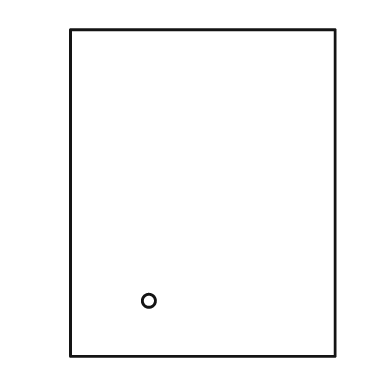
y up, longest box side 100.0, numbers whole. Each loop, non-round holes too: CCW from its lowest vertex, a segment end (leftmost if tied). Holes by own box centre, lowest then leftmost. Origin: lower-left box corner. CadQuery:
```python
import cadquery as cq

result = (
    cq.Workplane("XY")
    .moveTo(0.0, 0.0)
    .lineTo(81.0, 0.0)
    .lineTo(81.0, 100.0)
    .lineTo(0.0, 100.0)
    .close()
    .moveTo(24.0, 17.0)
    .circle(2.0)
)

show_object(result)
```